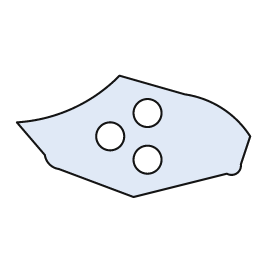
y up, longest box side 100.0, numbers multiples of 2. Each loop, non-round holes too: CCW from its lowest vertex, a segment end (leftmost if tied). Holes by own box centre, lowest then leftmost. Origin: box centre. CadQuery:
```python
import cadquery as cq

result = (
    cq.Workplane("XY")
    .moveTo(0.0, -26.0)
    .lineTo(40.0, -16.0)
    .threePointArc((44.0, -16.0), (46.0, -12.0))
    .lineTo(50.0, 0.0)
    .threePointArc((38.0, 12.0), (22.0, 18.0))
    .lineTo(-6.0, 26.0)
    .threePointArc((-26.0, 12.0), (-50.0, 6.0))
    .lineTo(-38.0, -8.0)
    .threePointArc((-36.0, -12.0), (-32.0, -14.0))
    .close()
    .moveTo(6.0, -10.0)
    .circle(6.0)
    .moveTo(-10.0, 0.0)
    .circle(6.0)
    .moveTo(6.0, 10.0)
    .circle(6.0)
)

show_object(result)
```